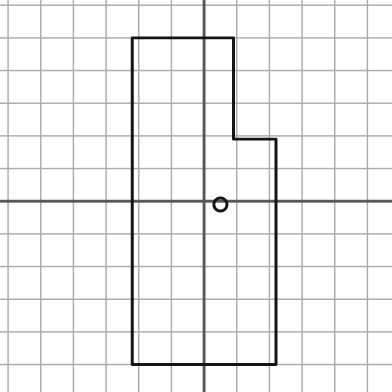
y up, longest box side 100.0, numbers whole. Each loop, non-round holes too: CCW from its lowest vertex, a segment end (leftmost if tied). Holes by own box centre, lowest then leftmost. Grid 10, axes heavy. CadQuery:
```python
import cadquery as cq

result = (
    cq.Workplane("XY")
    .moveTo(-22.0, -50.0)
    .lineTo(22.0, -50.0)
    .lineTo(22.0, 19.0)
    .lineTo(9.0, 19.0)
    .lineTo(9.0, 50.0)
    .lineTo(-22.0, 50.0)
    .close()
    .moveTo(5.0, -1.0)
    .circle(2.0)
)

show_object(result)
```